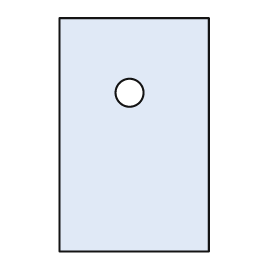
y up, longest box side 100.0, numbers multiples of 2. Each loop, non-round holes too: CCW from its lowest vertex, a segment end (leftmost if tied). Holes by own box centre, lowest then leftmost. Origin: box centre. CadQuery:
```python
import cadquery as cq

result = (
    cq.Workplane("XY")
    .moveTo(-32.0, -50.0)
    .lineTo(32.0, -50.0)
    .lineTo(32.0, 50.0)
    .lineTo(-32.0, 50.0)
    .close()
    .moveTo(-2.0, 18.0)
    .circle(6.0)
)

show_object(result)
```